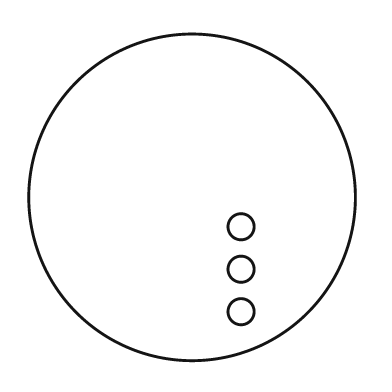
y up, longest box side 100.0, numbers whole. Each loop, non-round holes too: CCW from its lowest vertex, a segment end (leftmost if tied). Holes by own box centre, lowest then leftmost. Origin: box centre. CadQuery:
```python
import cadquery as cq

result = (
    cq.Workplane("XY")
    .moveTo(0.0, 0.0)
    .circle(50.0)
    .moveTo(15.0, -35.0)
    .circle(4.0)
    .moveTo(15.0, -22.0)
    .circle(4.0)
    .moveTo(15.0, -9.0)
    .circle(4.0)
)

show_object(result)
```